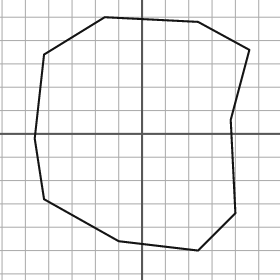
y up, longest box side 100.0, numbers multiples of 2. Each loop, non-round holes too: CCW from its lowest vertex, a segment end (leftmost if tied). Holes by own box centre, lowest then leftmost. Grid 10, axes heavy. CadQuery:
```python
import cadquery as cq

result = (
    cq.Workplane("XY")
    .moveTo(24.0, -50.0)
    .lineTo(40.0, -34.0)
    .lineTo(38.0, 6.0)
    .lineTo(46.0, 36.0)
    .lineTo(24.0, 48.0)
    .lineTo(-16.0, 50.0)
    .lineTo(-42.0, 34.0)
    .lineTo(-46.0, -2.0)
    .lineTo(-42.0, -28.0)
    .lineTo(-10.0, -46.0)
    .close()
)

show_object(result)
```